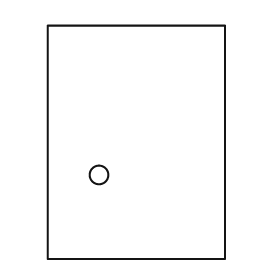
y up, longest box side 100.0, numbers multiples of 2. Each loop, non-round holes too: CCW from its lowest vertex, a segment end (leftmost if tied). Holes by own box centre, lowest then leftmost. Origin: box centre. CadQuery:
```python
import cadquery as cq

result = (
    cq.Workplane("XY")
    .moveTo(-38.0, -50.0)
    .lineTo(38.0, -50.0)
    .lineTo(38.0, 50.0)
    .lineTo(-38.0, 50.0)
    .close()
    .moveTo(-16.0, -14.0)
    .circle(4.0)
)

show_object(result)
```